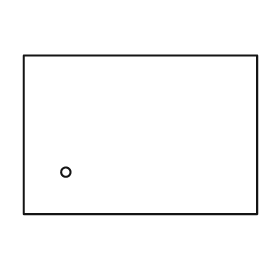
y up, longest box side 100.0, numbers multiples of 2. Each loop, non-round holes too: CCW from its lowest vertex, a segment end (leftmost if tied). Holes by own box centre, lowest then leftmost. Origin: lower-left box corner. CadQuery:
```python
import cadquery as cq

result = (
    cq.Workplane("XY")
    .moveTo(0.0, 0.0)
    .lineTo(100.0, 0.0)
    .lineTo(100.0, 68.0)
    .lineTo(0.0, 68.0)
    .close()
    .moveTo(18.0, 18.0)
    .circle(2.0)
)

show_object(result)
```